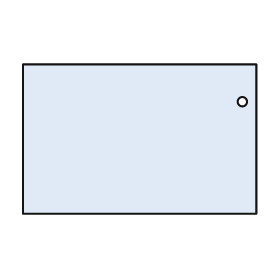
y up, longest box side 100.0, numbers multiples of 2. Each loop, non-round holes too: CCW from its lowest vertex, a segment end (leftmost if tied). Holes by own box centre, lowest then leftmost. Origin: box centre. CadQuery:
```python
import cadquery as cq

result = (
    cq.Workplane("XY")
    .moveTo(-50.0, -32.0)
    .lineTo(50.0, -32.0)
    .lineTo(50.0, 32.0)
    .lineTo(-50.0, 32.0)
    .close()
    .moveTo(44.0, 16.0)
    .circle(2.0)
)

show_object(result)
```